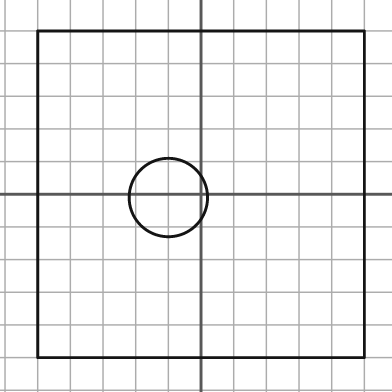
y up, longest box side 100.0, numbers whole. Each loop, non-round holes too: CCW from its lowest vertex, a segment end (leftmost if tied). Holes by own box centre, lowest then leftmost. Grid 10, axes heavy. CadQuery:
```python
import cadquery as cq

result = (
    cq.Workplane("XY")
    .moveTo(-50.0, -50.0)
    .lineTo(50.0, -50.0)
    .lineTo(50.0, 50.0)
    .lineTo(-50.0, 50.0)
    .close()
    .moveTo(-10.0, -1.0)
    .circle(12.0)
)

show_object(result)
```